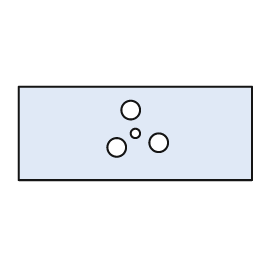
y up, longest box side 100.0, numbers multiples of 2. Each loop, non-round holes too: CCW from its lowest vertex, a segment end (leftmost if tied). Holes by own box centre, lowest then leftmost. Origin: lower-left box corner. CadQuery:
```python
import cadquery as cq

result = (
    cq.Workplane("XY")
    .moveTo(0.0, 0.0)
    .lineTo(100.0, 0.0)
    .lineTo(100.0, 40.0)
    .lineTo(0.0, 40.0)
    .close()
    .moveTo(42.0, 14.0)
    .circle(4.0)
    .moveTo(60.0, 16.0)
    .circle(4.0)
    .moveTo(50.0, 20.0)
    .circle(2.0)
    .moveTo(48.0, 30.0)
    .circle(4.0)
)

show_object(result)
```